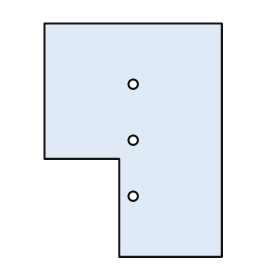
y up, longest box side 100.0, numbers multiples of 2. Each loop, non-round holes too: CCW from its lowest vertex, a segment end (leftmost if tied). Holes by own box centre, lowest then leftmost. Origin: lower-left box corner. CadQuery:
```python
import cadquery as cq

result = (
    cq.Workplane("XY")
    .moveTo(32.0, 0.0)
    .lineTo(76.0, 0.0)
    .lineTo(76.0, 100.0)
    .lineTo(0.0, 100.0)
    .lineTo(0.0, 42.0)
    .lineTo(32.0, 42.0)
    .close()
    .moveTo(38.0, 26.0)
    .circle(2.0)
    .moveTo(38.0, 50.0)
    .circle(2.0)
    .moveTo(38.0, 74.0)
    .circle(2.0)
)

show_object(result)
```